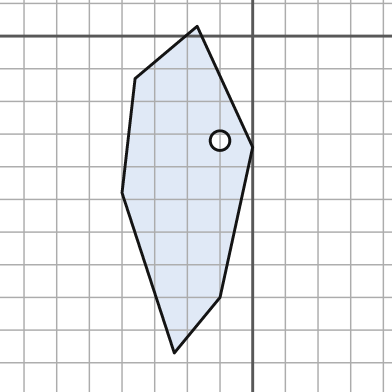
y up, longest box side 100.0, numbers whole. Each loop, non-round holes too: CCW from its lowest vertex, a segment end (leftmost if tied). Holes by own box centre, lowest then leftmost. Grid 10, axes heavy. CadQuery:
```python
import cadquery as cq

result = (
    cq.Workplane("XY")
    .moveTo(-24.0, -97.0)
    .lineTo(-10.0, -80.0)
    .lineTo(0.0, -34.0)
    .lineTo(-17.0, 3.0)
    .lineTo(-36.0, -13.0)
    .lineTo(-40.0, -48.0)
    .close()
    .moveTo(-10.0, -32.0)
    .circle(3.0)
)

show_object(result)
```